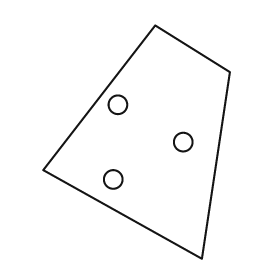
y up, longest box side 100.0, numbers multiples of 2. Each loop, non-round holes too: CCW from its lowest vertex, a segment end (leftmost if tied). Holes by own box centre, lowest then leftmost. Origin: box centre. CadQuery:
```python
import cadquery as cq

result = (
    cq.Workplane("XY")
    .moveTo(28.0, -50.0)
    .lineTo(40.0, 30.0)
    .lineTo(8.0, 50.0)
    .lineTo(-40.0, -12.0)
    .close()
    .moveTo(-10.0, -16.0)
    .circle(4.0)
    .moveTo(20.0, 0.0)
    .circle(4.0)
    .moveTo(-8.0, 16.0)
    .circle(4.0)
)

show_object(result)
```